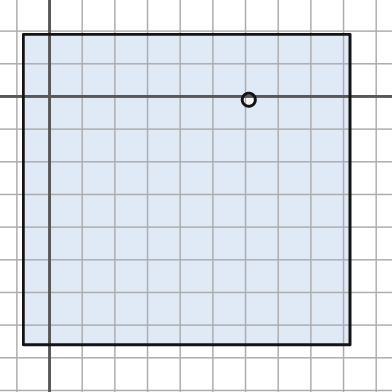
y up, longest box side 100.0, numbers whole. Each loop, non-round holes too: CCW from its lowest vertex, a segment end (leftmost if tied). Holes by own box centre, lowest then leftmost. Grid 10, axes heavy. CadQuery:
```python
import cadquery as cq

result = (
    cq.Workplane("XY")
    .moveTo(-8.0, -76.0)
    .lineTo(92.0, -76.0)
    .lineTo(92.0, 19.0)
    .lineTo(-8.0, 19.0)
    .close()
    .moveTo(61.0, -1.0)
    .circle(2.0)
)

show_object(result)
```